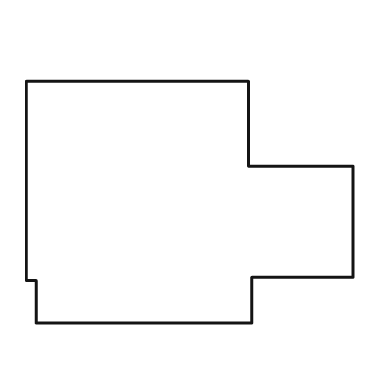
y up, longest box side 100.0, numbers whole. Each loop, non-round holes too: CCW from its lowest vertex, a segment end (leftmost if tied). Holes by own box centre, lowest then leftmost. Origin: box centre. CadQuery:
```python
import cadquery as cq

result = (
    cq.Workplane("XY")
    .moveTo(-47.0, -37.0)
    .lineTo(19.0, -37.0)
    .lineTo(19.0, -23.0)
    .lineTo(50.0, -23.0)
    .lineTo(50.0, 11.0)
    .lineTo(18.0, 11.0)
    .lineTo(18.0, 37.0)
    .lineTo(-50.0, 37.0)
    .lineTo(-50.0, -24.0)
    .lineTo(-47.0, -24.0)
    .close()
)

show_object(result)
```